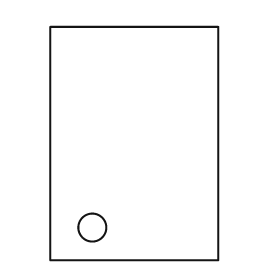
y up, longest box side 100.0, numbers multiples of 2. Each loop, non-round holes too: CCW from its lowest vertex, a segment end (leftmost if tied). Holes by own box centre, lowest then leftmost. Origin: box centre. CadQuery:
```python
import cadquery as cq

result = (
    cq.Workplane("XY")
    .moveTo(-36.0, -50.0)
    .lineTo(36.0, -50.0)
    .lineTo(36.0, 50.0)
    .lineTo(-36.0, 50.0)
    .close()
    .moveTo(-18.0, -36.0)
    .circle(6.0)
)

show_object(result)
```